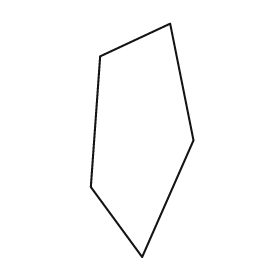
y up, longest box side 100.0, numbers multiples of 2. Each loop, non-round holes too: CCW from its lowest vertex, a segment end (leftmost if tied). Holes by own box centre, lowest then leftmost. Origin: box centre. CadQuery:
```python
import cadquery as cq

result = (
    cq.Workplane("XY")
    .moveTo(0.0, -50.0)
    .lineTo(22.0, 0.0)
    .lineTo(12.0, 50.0)
    .lineTo(-18.0, 36.0)
    .lineTo(-22.0, -20.0)
    .close()
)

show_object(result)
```